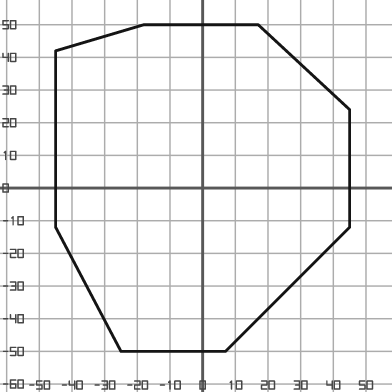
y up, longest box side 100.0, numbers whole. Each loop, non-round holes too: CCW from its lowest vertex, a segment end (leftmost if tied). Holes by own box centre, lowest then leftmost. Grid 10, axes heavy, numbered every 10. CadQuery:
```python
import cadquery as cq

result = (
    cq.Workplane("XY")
    .moveTo(-25.0, -50.0)
    .lineTo(7.0, -50.0)
    .lineTo(45.0, -12.0)
    .lineTo(45.0, 24.0)
    .lineTo(17.0, 50.0)
    .lineTo(-18.0, 50.0)
    .lineTo(-45.0, 42.0)
    .lineTo(-45.0, -12.0)
    .close()
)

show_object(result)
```